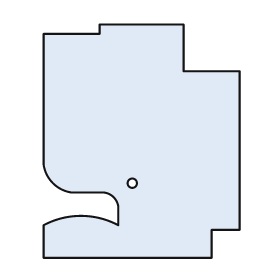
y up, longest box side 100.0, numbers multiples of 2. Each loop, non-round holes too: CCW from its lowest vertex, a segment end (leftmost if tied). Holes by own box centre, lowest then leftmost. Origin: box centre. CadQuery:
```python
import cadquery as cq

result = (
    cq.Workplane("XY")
    .moveTo(-42.0, -50.0)
    .lineTo(30.0, -50.0)
    .lineTo(30.0, -38.0)
    .lineTo(42.0, -38.0)
    .lineTo(42.0, 30.0)
    .lineTo(18.0, 30.0)
    .lineTo(18.0, 50.0)
    .lineTo(-18.0, 50.0)
    .lineTo(-18.0, 46.0)
    .lineTo(-42.0, 46.0)
    .lineTo(-42.0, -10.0)
    .threePointArc((-38.0, -18.0), (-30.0, -22.0))
    .lineTo(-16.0, -22.0)
    .threePointArc((-12.0, -24.0), (-10.0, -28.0))
    .lineTo(-10.0, -36.0)
    .threePointArc((-26.0, -32.0), (-42.0, -36.0))
    .close()
    .moveTo(-4.0, -18.0)
    .circle(2.0)
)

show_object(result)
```